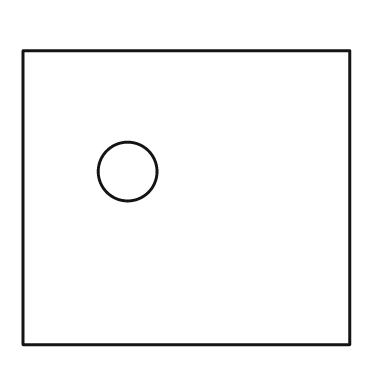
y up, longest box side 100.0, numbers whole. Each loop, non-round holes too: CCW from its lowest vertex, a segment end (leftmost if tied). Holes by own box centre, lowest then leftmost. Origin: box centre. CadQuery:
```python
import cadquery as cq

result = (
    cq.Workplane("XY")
    .moveTo(-50.0, -45.0)
    .lineTo(50.0, -45.0)
    .lineTo(50.0, 45.0)
    .lineTo(-50.0, 45.0)
    .close()
    .moveTo(-18.0, 8.0)
    .circle(9.0)
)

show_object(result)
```